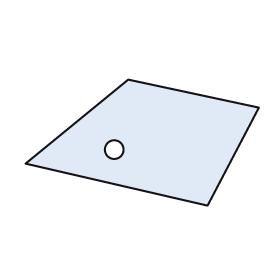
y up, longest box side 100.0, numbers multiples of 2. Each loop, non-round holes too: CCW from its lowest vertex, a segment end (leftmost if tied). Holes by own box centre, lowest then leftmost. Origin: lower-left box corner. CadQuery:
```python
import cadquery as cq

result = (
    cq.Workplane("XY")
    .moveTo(78.0, 0.0)
    .lineTo(100.0, 42.0)
    .lineTo(44.0, 54.0)
    .lineTo(0.0, 18.0)
    .close()
    .moveTo(38.0, 24.0)
    .circle(4.0)
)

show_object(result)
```